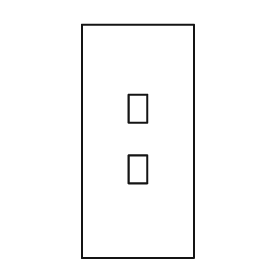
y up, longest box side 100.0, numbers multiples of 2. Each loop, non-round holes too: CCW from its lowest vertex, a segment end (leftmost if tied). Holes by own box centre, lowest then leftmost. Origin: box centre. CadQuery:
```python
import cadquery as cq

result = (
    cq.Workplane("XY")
    .moveTo(-24.0, -50.0)
    .lineTo(24.0, -50.0)
    .lineTo(24.0, 50.0)
    .lineTo(-24.0, 50.0)
    .close()
    .moveTo(-4.0, -18.0)
    .lineTo(4.0, -18.0)
    .lineTo(4.0, -6.0)
    .lineTo(-4.0, -6.0)
    .close()
    .moveTo(-4.0, 8.0)
    .lineTo(4.0, 8.0)
    .lineTo(4.0, 20.0)
    .lineTo(-4.0, 20.0)
    .close()
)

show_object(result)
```